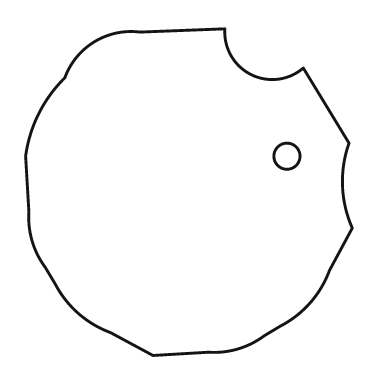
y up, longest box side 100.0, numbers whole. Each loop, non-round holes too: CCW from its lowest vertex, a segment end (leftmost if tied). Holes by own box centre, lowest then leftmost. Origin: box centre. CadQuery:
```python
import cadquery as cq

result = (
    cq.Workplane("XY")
    .moveTo(-11.0, -50.0)
    .lineTo(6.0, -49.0)
    .threePointArc((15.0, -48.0), (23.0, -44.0))
    .lineTo(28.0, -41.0)
    .threePointArc((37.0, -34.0), (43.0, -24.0))
    .lineTo(50.0, -11.0)
    .threePointArc((47.0, 2.0), (49.0, 15.0))
    .lineTo(35.0, 38.0)
    .threePointArc((19.0, 36.0), (11.0, 50.0))
    .lineTo(-15.0, 49.0)
    .threePointArc((-29.0, 46.0), (-38.0, 35.0))
    .threePointArc((-46.0, 24.0), (-50.0, 11.0))
    .lineTo(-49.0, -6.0)
    .threePointArc((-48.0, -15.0), (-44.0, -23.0))
    .lineTo(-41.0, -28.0)
    .threePointArc((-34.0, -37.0), (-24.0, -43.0))
    .close()
    .moveTo(30.0, 11.0)
    .circle(4.0)
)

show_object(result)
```